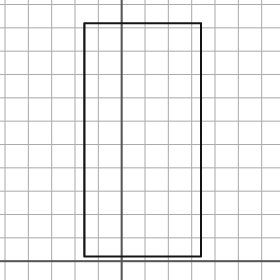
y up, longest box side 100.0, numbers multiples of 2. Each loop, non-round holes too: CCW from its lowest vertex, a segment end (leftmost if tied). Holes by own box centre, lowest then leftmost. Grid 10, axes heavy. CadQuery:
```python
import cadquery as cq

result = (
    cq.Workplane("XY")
    .moveTo(-16.0, 2.0)
    .lineTo(34.0, 2.0)
    .lineTo(34.0, 102.0)
    .lineTo(-16.0, 102.0)
    .close()
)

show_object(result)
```